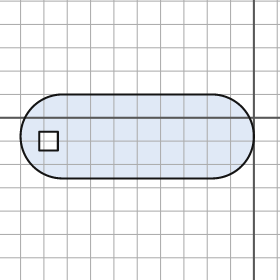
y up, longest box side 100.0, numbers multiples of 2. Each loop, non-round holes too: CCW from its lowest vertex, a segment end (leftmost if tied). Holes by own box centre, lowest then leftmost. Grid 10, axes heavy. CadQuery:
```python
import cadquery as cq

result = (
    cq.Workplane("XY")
    .moveTo(-82.0, -26.0)
    .lineTo(-18.0, -26.0)
    .threePointArc((0.0, -8.0), (-18.0, 10.0))
    .lineTo(-82.0, 10.0)
    .threePointArc((-100.0, -8.0), (-82.0, -26.0))
    .close()
    .moveTo(-92.0, -14.0)
    .lineTo(-84.0, -14.0)
    .lineTo(-84.0, -6.0)
    .lineTo(-92.0, -6.0)
    .close()
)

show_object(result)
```